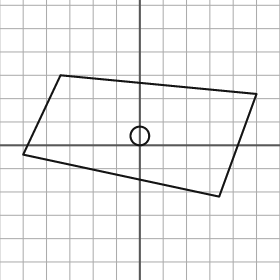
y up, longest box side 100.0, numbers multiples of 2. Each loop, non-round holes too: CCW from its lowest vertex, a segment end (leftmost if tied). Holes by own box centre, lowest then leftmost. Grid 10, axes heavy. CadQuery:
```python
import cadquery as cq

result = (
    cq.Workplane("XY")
    .moveTo(34.0, -22.0)
    .lineTo(50.0, 22.0)
    .lineTo(-34.0, 30.0)
    .lineTo(-50.0, -4.0)
    .close()
    .moveTo(0.0, 4.0)
    .circle(4.0)
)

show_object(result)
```